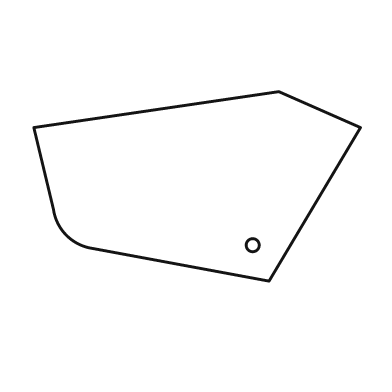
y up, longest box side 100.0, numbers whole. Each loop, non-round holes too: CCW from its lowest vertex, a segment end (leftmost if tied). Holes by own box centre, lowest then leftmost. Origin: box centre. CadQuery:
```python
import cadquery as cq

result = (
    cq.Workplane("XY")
    .moveTo(22.0, -29.0)
    .lineTo(50.0, 18.0)
    .lineTo(25.0, 29.0)
    .lineTo(-50.0, 18.0)
    .lineTo(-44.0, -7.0)
    .threePointArc((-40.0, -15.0), (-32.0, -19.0))
    .close()
    .moveTo(17.0, -18.0)
    .circle(2.0)
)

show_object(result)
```